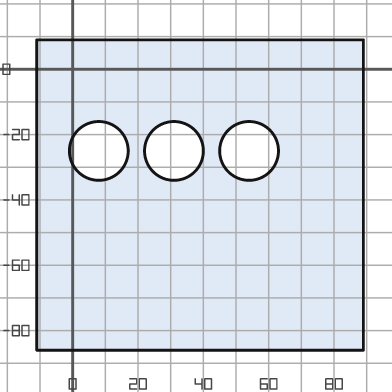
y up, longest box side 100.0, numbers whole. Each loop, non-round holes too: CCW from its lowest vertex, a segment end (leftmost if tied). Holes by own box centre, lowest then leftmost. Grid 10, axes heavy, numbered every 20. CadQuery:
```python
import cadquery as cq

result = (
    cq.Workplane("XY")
    .moveTo(-11.0, -86.0)
    .lineTo(89.0, -86.0)
    .lineTo(89.0, 9.0)
    .lineTo(-11.0, 9.0)
    .close()
    .moveTo(8.0, -25.0)
    .circle(9.0)
    .moveTo(31.0, -25.0)
    .circle(9.0)
    .moveTo(54.0, -25.0)
    .circle(9.0)
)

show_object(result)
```